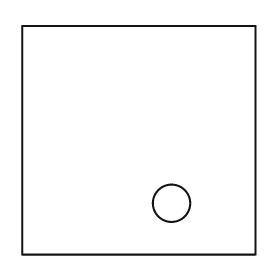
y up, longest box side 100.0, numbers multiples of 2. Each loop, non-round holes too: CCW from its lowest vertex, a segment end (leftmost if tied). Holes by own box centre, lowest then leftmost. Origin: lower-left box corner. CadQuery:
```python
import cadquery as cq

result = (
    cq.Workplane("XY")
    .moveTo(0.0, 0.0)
    .lineTo(100.0, 0.0)
    .lineTo(100.0, 98.0)
    .lineTo(0.0, 98.0)
    .close()
    .moveTo(64.0, 22.0)
    .circle(8.0)
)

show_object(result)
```